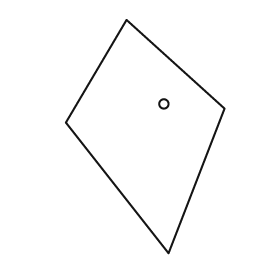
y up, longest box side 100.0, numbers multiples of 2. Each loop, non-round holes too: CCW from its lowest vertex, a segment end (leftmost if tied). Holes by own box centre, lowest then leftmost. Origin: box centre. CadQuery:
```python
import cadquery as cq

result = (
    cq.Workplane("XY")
    .moveTo(10.0, -50.0)
    .lineTo(34.0, 12.0)
    .lineTo(-8.0, 50.0)
    .lineTo(-34.0, 6.0)
    .close()
    .moveTo(8.0, 14.0)
    .circle(2.0)
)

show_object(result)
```